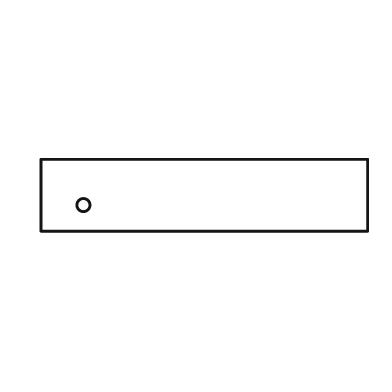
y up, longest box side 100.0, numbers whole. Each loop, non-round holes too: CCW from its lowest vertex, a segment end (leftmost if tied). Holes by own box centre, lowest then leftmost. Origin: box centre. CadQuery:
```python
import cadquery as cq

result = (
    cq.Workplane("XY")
    .moveTo(-50.0, -11.0)
    .lineTo(50.0, -11.0)
    .lineTo(50.0, 11.0)
    .lineTo(-50.0, 11.0)
    .close()
    .moveTo(-37.0, -3.0)
    .circle(2.0)
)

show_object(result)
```